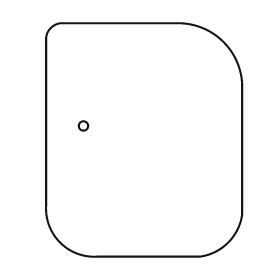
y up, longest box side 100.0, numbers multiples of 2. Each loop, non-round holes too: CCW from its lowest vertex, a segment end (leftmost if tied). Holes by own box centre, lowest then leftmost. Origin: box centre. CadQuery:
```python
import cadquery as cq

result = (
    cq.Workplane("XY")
    .moveTo(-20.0, -50.0)
    .lineTo(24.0, -50.0)
    .threePointArc((36.0, -44.0), (42.0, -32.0))
    .lineTo(42.0, 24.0)
    .threePointArc((34.0, 42.0), (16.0, 50.0))
    .lineTo(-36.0, 50.0)
    .threePointArc((-40.0, 48.0), (-42.0, 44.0))
    .lineTo(-42.0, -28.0)
    .threePointArc((-36.0, -44.0), (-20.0, -50.0))
    .close()
    .moveTo(-26.0, 6.0)
    .circle(2.0)
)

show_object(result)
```